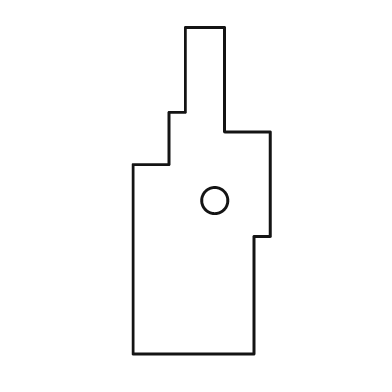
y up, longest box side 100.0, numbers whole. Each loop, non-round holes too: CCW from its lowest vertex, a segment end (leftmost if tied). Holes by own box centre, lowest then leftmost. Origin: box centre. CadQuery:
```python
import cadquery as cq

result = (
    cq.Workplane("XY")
    .moveTo(-21.0, -50.0)
    .lineTo(16.0, -50.0)
    .lineTo(16.0, -14.0)
    .lineTo(21.0, -14.0)
    .lineTo(21.0, 18.0)
    .lineTo(7.0, 18.0)
    .lineTo(7.0, 50.0)
    .lineTo(-5.0, 50.0)
    .lineTo(-5.0, 24.0)
    .lineTo(-10.0, 24.0)
    .lineTo(-10.0, 8.0)
    .lineTo(-21.0, 8.0)
    .close()
    .moveTo(4.0, -3.0)
    .circle(4.0)
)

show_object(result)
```